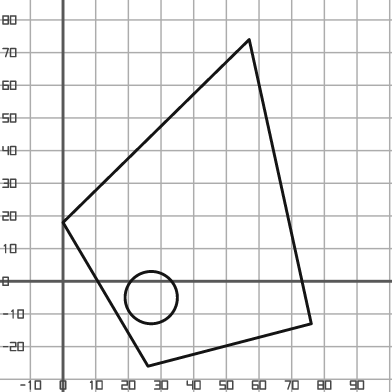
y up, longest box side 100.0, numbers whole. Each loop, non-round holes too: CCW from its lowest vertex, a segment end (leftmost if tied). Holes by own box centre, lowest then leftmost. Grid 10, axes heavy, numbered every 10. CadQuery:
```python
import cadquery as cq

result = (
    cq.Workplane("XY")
    .moveTo(26.0, -26.0)
    .lineTo(76.0, -13.0)
    .lineTo(57.0, 74.0)
    .lineTo(0.0, 18.0)
    .close()
    .moveTo(27.0, -5.0)
    .circle(8.0)
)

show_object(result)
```